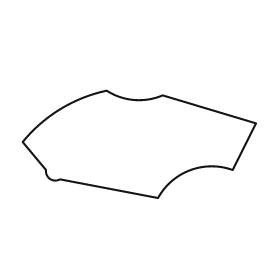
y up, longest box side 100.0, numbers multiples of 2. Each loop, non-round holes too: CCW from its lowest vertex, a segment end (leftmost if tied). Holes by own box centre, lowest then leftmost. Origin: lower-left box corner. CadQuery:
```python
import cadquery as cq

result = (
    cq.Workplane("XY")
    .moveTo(58.0, 0.0)
    .threePointArc((72.0, 12.0), (90.0, 12.0))
    .lineTo(100.0, 32.0)
    .lineTo(60.0, 44.0)
    .threePointArc((48.0, 42.0), (36.0, 46.0))
    .threePointArc((16.0, 38.0), (0.0, 24.0))
    .lineTo(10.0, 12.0)
    .threePointArc((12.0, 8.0), (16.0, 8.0))
    .close()
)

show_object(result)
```